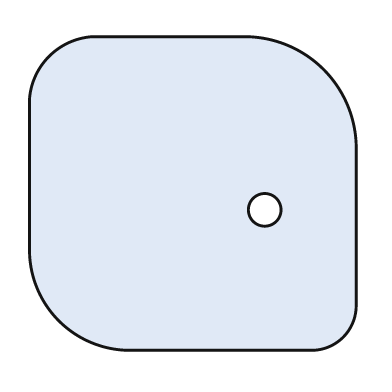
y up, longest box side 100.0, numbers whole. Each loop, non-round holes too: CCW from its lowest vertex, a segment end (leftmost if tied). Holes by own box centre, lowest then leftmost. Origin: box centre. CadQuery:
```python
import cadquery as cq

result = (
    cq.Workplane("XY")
    .moveTo(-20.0, -48.0)
    .lineTo(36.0, -48.0)
    .threePointArc((46.0, -44.0), (50.0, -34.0))
    .lineTo(50.0, 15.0)
    .threePointArc((40.0, 38.0), (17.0, 48.0))
    .lineTo(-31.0, 48.0)
    .threePointArc((-44.0, 42.0), (-50.0, 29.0))
    .lineTo(-50.0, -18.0)
    .threePointArc((-41.0, -39.0), (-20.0, -48.0))
    .close()
    .moveTo(22.0, -5.0)
    .circle(5.0)
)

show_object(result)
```